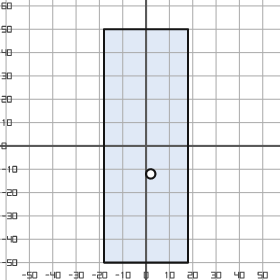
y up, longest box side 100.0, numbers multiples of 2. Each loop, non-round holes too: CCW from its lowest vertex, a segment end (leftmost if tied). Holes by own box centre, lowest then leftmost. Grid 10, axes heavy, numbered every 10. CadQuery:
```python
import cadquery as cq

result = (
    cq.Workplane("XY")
    .moveTo(-18.0, -50.0)
    .lineTo(18.0, -50.0)
    .lineTo(18.0, 50.0)
    .lineTo(-18.0, 50.0)
    .close()
    .moveTo(2.0, -12.0)
    .circle(2.0)
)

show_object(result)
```